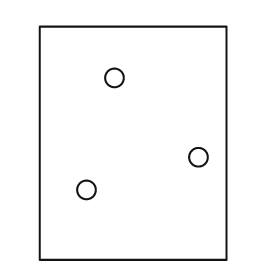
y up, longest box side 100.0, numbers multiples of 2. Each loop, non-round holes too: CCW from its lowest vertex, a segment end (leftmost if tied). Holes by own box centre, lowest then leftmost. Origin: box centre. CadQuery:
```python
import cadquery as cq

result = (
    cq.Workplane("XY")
    .moveTo(-40.0, -50.0)
    .lineTo(40.0, -50.0)
    .lineTo(40.0, 50.0)
    .lineTo(-40.0, 50.0)
    .close()
    .moveTo(-20.0, -20.0)
    .circle(4.0)
    .moveTo(28.0, -6.0)
    .circle(4.0)
    .moveTo(-8.0, 28.0)
    .circle(4.0)
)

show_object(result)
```